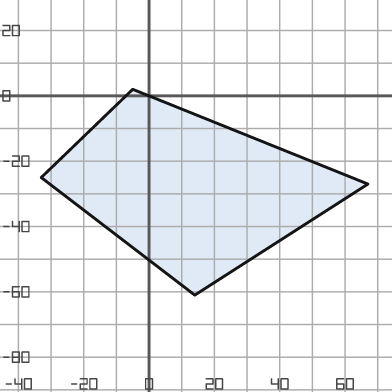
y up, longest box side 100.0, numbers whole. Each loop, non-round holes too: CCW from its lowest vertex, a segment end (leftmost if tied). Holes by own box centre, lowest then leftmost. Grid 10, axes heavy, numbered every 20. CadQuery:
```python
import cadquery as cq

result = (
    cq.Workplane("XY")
    .moveTo(14.0, -61.0)
    .lineTo(67.0, -27.0)
    .lineTo(-5.0, 2.0)
    .lineTo(-33.0, -25.0)
    .close()
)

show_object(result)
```